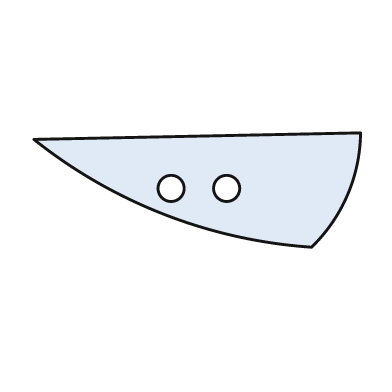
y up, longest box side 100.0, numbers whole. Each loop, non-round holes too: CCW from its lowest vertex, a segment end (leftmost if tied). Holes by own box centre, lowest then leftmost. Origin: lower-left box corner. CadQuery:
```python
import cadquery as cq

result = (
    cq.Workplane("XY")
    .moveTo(85.0, 0.0)
    .threePointArc((96.0, 16.0), (100.0, 35.0))
    .lineTo(0.0, 33.0)
    .threePointArc((40.0, 10.0), (85.0, 0.0))
    .close()
    .moveTo(42.0, 18.0)
    .circle(4.0)
    .moveTo(59.0, 18.0)
    .circle(4.0)
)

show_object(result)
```